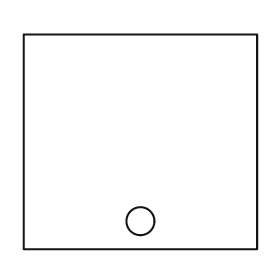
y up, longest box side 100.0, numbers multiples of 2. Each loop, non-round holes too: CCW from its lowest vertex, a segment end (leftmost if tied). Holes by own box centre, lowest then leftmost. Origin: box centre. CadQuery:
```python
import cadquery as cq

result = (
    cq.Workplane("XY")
    .moveTo(-50.0, -46.0)
    .lineTo(50.0, -46.0)
    .lineTo(50.0, 46.0)
    .lineTo(-50.0, 46.0)
    .close()
    .moveTo(0.0, -34.0)
    .circle(6.0)
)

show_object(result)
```